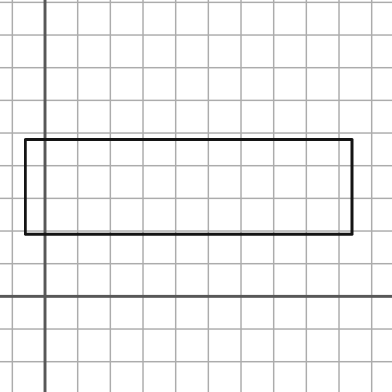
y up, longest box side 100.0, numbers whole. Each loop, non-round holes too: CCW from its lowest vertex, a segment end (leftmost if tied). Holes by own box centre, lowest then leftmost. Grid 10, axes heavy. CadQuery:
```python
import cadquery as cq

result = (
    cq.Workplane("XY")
    .moveTo(-6.0, 19.0)
    .lineTo(94.0, 19.0)
    .lineTo(94.0, 48.0)
    .lineTo(-6.0, 48.0)
    .close()
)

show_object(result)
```